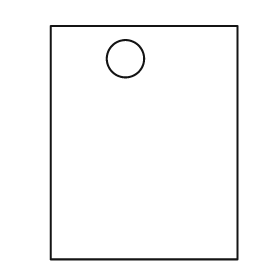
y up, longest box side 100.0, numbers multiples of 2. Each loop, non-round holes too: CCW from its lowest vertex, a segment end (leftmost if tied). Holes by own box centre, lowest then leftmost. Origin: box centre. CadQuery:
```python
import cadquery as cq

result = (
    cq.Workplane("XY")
    .moveTo(-40.0, -50.0)
    .lineTo(40.0, -50.0)
    .lineTo(40.0, 50.0)
    .lineTo(-40.0, 50.0)
    .close()
    .moveTo(-8.0, 36.0)
    .circle(8.0)
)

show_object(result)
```